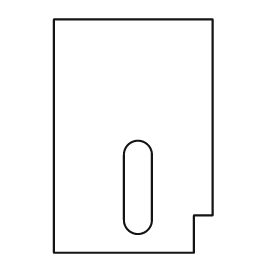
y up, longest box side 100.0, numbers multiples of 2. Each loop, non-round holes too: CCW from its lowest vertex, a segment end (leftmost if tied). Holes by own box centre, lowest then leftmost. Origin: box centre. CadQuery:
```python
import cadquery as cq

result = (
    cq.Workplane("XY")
    .moveTo(-34.0, -50.0)
    .lineTo(26.0, -50.0)
    .lineTo(26.0, -34.0)
    .lineTo(34.0, -34.0)
    .lineTo(34.0, 50.0)
    .lineTo(-34.0, 50.0)
    .close()
    .moveTo(-4.0, -36.0)
    .threePointArc((2.0, -42.0), (8.0, -36.0))
    .lineTo(8.0, -8.0)
    .threePointArc((2.0, -2.0), (-4.0, -8.0))
    .close()
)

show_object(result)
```